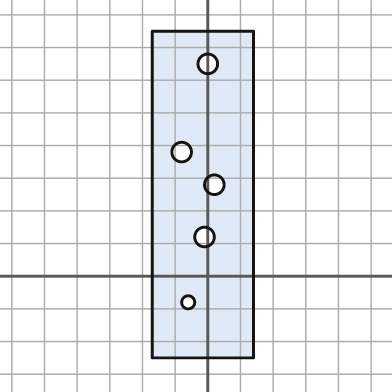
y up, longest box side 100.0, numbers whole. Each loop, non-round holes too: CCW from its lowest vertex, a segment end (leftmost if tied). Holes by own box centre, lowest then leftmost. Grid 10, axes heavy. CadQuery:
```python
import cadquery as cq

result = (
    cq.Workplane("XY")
    .moveTo(-17.0, -25.0)
    .lineTo(14.0, -25.0)
    .lineTo(14.0, 75.0)
    .lineTo(-17.0, 75.0)
    .close()
    .moveTo(-6.0, -8.0)
    .circle(2.0)
    .moveTo(-1.0, 12.0)
    .circle(3.0)
    .moveTo(2.0, 28.0)
    .circle(3.0)
    .moveTo(-8.0, 38.0)
    .circle(3.0)
    .moveTo(0.0, 65.0)
    .circle(3.0)
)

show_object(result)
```